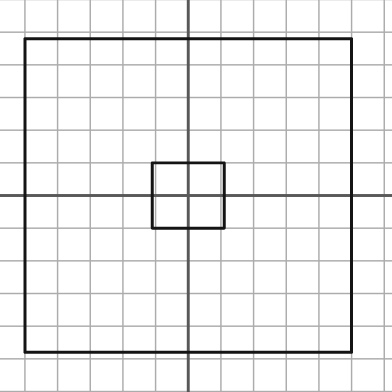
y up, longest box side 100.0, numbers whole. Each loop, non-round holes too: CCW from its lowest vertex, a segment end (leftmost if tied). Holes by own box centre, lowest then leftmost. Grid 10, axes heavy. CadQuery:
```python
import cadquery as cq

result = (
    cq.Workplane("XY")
    .moveTo(-50.0, -48.0)
    .lineTo(50.0, -48.0)
    .lineTo(50.0, 48.0)
    .lineTo(-50.0, 48.0)
    .close()
    .moveTo(-11.0, -10.0)
    .lineTo(11.0, -10.0)
    .lineTo(11.0, 10.0)
    .lineTo(-11.0, 10.0)
    .close()
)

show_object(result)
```